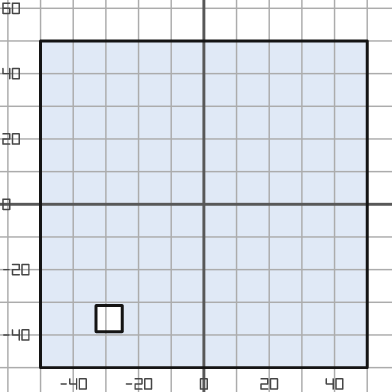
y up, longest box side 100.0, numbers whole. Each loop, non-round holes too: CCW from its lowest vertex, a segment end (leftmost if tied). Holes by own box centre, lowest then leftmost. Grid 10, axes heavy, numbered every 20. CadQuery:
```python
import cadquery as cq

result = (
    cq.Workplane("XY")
    .moveTo(-50.0, -50.0)
    .lineTo(50.0, -50.0)
    .lineTo(50.0, 50.0)
    .lineTo(-50.0, 50.0)
    .close()
    .moveTo(-33.0, -39.0)
    .lineTo(-25.0, -39.0)
    .lineTo(-25.0, -31.0)
    .lineTo(-33.0, -31.0)
    .close()
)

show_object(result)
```